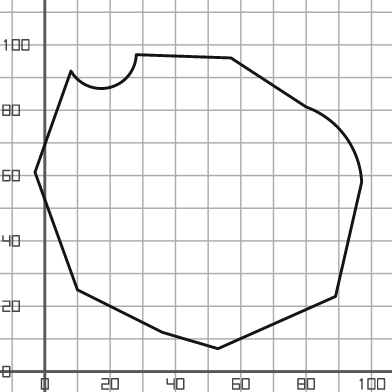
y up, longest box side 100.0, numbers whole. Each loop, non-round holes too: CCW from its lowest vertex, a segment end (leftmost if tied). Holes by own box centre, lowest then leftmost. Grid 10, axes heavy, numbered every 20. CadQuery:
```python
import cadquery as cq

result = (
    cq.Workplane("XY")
    .moveTo(53.0, 7.0)
    .lineTo(89.0, 23.0)
    .lineTo(97.0, 58.0)
    .threePointArc((92.0, 72.0), (80.0, 81.0))
    .lineTo(57.0, 96.0)
    .lineTo(28.0, 97.0)
    .threePointArc((20.0, 87.0), (8.0, 92.0))
    .lineTo(-3.0, 61.0)
    .lineTo(10.0, 25.0)
    .lineTo(36.0, 12.0)
    .close()
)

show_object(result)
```